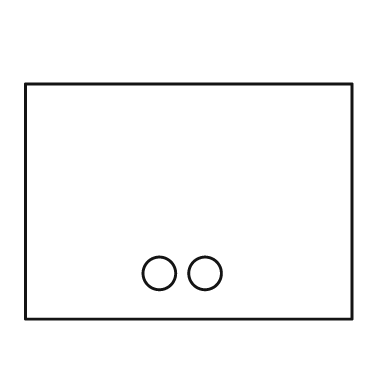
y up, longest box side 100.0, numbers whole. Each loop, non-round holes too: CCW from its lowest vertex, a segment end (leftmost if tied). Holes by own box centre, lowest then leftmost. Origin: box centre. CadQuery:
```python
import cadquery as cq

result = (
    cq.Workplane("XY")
    .moveTo(-50.0, -36.0)
    .lineTo(50.0, -36.0)
    .lineTo(50.0, 36.0)
    .lineTo(-50.0, 36.0)
    .close()
    .moveTo(-9.0, -22.0)
    .circle(5.0)
    .moveTo(5.0, -22.0)
    .circle(5.0)
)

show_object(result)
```